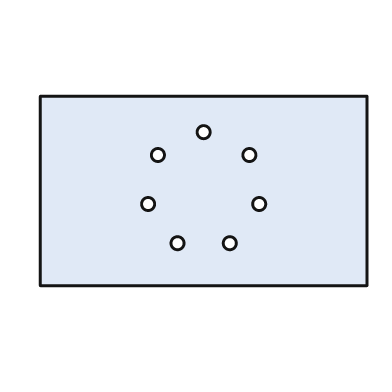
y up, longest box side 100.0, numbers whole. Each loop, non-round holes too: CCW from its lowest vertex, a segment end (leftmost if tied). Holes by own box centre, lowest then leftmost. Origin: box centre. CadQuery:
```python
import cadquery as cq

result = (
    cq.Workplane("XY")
    .moveTo(-50.0, -29.0)
    .lineTo(50.0, -29.0)
    .lineTo(50.0, 29.0)
    .lineTo(-50.0, 29.0)
    .close()
    .moveTo(-8.0, -16.0)
    .circle(2.0)
    .moveTo(8.0, -16.0)
    .circle(2.0)
    .moveTo(-17.0, -4.0)
    .circle(2.0)
    .moveTo(17.0, -4.0)
    .circle(2.0)
    .moveTo(-14.0, 11.0)
    .circle(2.0)
    .moveTo(14.0, 11.0)
    .circle(2.0)
    .moveTo(0.0, 18.0)
    .circle(2.0)
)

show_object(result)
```